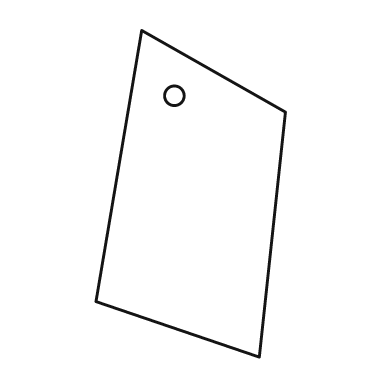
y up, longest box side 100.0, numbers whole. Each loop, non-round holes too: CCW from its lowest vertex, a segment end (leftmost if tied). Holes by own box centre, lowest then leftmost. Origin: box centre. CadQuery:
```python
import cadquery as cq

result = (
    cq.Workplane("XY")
    .moveTo(21.0, -50.0)
    .lineTo(29.0, 25.0)
    .lineTo(-15.0, 50.0)
    .lineTo(-29.0, -33.0)
    .close()
    .moveTo(-5.0, 30.0)
    .circle(3.0)
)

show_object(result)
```